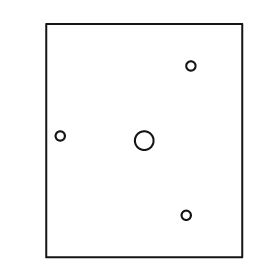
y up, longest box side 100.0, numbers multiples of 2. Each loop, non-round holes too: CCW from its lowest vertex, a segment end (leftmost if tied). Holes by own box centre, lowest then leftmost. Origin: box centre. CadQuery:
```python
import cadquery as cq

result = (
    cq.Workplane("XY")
    .moveTo(-42.0, -50.0)
    .lineTo(42.0, -50.0)
    .lineTo(42.0, 50.0)
    .lineTo(-42.0, 50.0)
    .close()
    .moveTo(18.0, -32.0)
    .circle(2.0)
    .moveTo(0.0, 0.0)
    .circle(4.0)
    .moveTo(-36.0, 2.0)
    .circle(2.0)
    .moveTo(20.0, 32.0)
    .circle(2.0)
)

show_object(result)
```